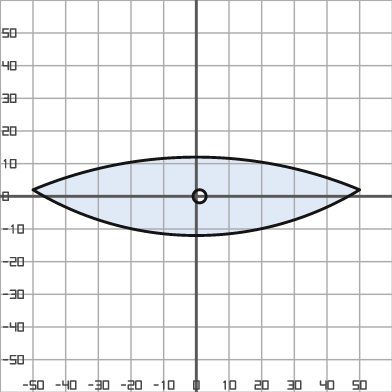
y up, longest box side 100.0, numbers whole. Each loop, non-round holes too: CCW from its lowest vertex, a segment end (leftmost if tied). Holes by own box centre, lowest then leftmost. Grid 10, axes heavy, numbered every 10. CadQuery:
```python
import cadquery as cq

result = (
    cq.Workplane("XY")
    .moveTo(-50.0, 2.0)
    .threePointArc((0.0, -12.0), (50.0, 2.0))
    .threePointArc((0.0, 12.0), (-50.0, 2.0))
    .close()
    .moveTo(1.0, 0.0)
    .circle(2.0)
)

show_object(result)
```